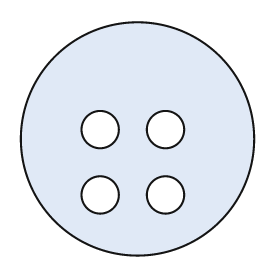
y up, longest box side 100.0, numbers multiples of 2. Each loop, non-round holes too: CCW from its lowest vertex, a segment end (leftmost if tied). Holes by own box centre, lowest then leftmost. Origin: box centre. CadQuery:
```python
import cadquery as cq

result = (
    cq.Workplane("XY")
    .moveTo(0.0, 0.0)
    .circle(50.0)
    .moveTo(-16.0, -24.0)
    .circle(8.0)
    .moveTo(12.0, -24.0)
    .circle(8.0)
    .moveTo(-16.0, 4.0)
    .circle(8.0)
    .moveTo(12.0, 4.0)
    .circle(8.0)
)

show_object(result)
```